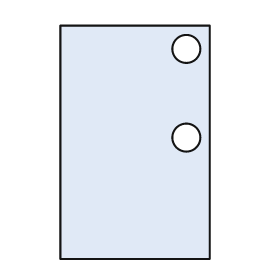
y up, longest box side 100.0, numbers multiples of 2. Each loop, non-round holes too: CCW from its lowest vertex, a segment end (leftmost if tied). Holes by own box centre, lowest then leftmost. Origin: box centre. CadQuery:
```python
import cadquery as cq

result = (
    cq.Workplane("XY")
    .moveTo(-32.0, -50.0)
    .lineTo(32.0, -50.0)
    .lineTo(32.0, 50.0)
    .lineTo(-32.0, 50.0)
    .close()
    .moveTo(22.0, 2.0)
    .circle(6.0)
    .moveTo(22.0, 40.0)
    .circle(6.0)
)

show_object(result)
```